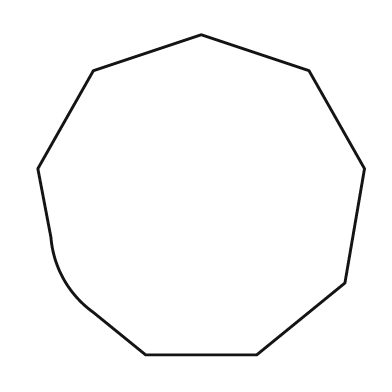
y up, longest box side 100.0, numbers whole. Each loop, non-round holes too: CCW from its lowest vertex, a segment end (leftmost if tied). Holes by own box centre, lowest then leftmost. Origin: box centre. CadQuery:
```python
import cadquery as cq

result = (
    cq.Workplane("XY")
    .moveTo(-17.0, -49.0)
    .lineTo(17.0, -49.0)
    .lineTo(44.0, -27.0)
    .lineTo(50.0, 8.0)
    .lineTo(33.0, 38.0)
    .lineTo(0.0, 49.0)
    .lineTo(-33.0, 38.0)
    .lineTo(-50.0, 8.0)
    .lineTo(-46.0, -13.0)
    .threePointArc((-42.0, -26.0), (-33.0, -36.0))
    .close()
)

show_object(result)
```